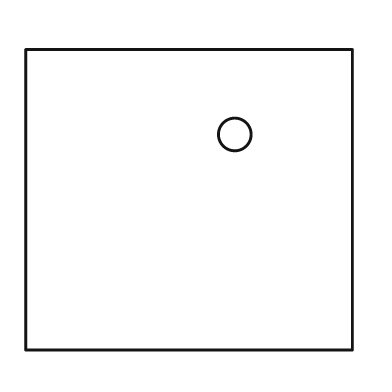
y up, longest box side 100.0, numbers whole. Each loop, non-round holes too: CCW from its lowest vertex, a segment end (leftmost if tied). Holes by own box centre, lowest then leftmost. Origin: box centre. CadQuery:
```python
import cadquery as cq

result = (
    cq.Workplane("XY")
    .moveTo(-50.0, -46.0)
    .lineTo(50.0, -46.0)
    .lineTo(50.0, 46.0)
    .lineTo(-50.0, 46.0)
    .close()
    .moveTo(14.0, 20.0)
    .circle(5.0)
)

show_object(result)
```